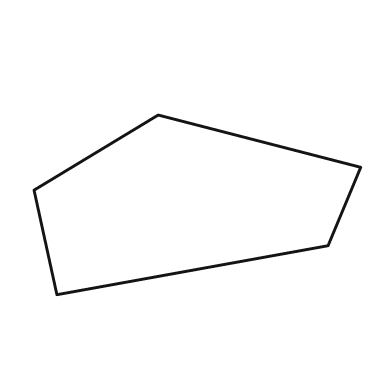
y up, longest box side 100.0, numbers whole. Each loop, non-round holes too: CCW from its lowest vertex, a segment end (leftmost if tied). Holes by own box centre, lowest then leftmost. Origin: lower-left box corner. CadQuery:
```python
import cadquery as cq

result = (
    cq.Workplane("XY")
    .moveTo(7.0, 0.0)
    .lineTo(90.0, 15.0)
    .lineTo(100.0, 39.0)
    .lineTo(38.0, 55.0)
    .lineTo(0.0, 32.0)
    .close()
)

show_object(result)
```